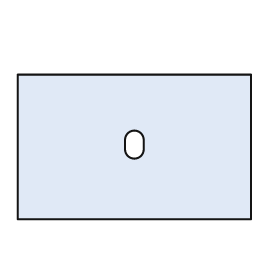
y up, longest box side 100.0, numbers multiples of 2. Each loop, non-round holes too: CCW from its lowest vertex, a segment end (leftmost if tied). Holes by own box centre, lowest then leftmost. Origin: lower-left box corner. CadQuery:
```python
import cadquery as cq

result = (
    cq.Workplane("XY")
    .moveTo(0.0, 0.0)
    .lineTo(100.0, 0.0)
    .lineTo(100.0, 62.0)
    .lineTo(0.0, 62.0)
    .close()
    .moveTo(46.0, 30.0)
    .threePointArc((50.0, 26.0), (54.0, 30.0))
    .lineTo(54.0, 34.0)
    .threePointArc((50.0, 38.0), (46.0, 34.0))
    .close()
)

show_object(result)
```